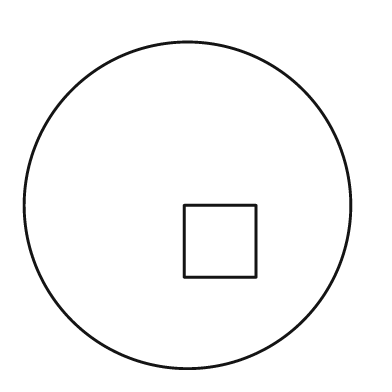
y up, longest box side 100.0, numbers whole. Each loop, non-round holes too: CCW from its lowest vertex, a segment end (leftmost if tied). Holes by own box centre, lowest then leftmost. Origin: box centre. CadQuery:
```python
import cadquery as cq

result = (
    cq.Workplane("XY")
    .moveTo(0.0, 0.0)
    .circle(50.0)
    .moveTo(-1.0, -22.0)
    .lineTo(21.0, -22.0)
    .lineTo(21.0, 0.0)
    .lineTo(-1.0, 0.0)
    .close()
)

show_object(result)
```